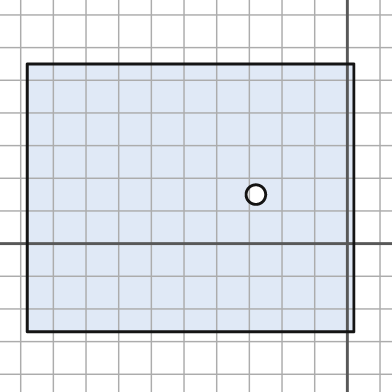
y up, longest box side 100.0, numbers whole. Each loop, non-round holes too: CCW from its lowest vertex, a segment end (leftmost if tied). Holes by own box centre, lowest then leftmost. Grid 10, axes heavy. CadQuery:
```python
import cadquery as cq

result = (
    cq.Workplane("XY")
    .moveTo(-98.0, -27.0)
    .lineTo(2.0, -27.0)
    .lineTo(2.0, 55.0)
    .lineTo(-98.0, 55.0)
    .close()
    .moveTo(-28.0, 15.0)
    .circle(3.0)
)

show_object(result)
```